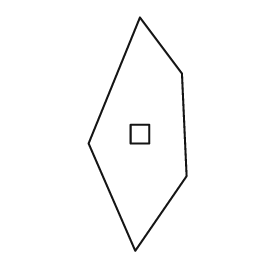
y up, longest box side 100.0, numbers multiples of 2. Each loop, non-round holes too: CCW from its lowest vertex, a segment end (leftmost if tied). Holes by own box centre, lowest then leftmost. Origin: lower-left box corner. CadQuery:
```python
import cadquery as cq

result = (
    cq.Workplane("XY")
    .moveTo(20.0, 0.0)
    .lineTo(42.0, 32.0)
    .lineTo(40.0, 76.0)
    .lineTo(22.0, 100.0)
    .lineTo(0.0, 46.0)
    .close()
    .moveTo(18.0, 46.0)
    .lineTo(26.0, 46.0)
    .lineTo(26.0, 54.0)
    .lineTo(18.0, 54.0)
    .close()
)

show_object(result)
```